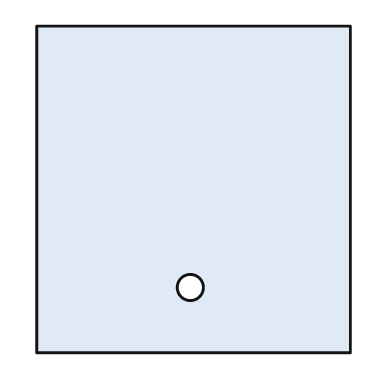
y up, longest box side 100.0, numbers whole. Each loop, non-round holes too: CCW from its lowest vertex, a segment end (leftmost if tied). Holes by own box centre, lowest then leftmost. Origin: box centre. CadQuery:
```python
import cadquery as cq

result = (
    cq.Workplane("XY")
    .moveTo(-48.0, -50.0)
    .lineTo(48.0, -50.0)
    .lineTo(48.0, 50.0)
    .lineTo(-48.0, 50.0)
    .close()
    .moveTo(-1.0, -30.0)
    .circle(4.0)
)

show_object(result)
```